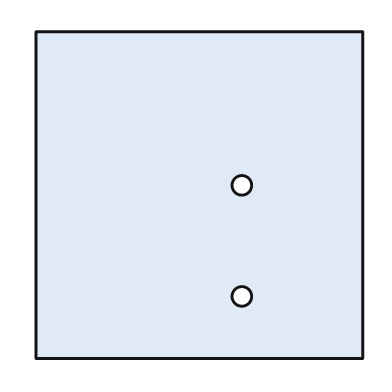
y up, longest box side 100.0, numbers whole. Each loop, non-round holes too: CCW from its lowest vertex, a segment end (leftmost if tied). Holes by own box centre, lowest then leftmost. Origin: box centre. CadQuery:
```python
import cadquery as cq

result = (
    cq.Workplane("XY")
    .moveTo(-50.0, -50.0)
    .lineTo(50.0, -50.0)
    .lineTo(50.0, 50.0)
    .lineTo(-50.0, 50.0)
    .close()
    .moveTo(13.0, -31.0)
    .circle(3.0)
    .moveTo(13.0, 3.0)
    .circle(3.0)
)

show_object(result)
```